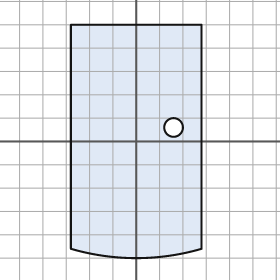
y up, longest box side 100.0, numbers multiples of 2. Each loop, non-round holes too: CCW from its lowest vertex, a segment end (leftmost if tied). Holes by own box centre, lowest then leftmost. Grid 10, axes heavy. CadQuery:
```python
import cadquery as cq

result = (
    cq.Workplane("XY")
    .moveTo(-28.0, -46.0)
    .threePointArc((0.0, -50.0), (28.0, -46.0))
    .lineTo(28.0, 50.0)
    .lineTo(-28.0, 50.0)
    .close()
    .moveTo(16.0, 6.0)
    .circle(4.0)
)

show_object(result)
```